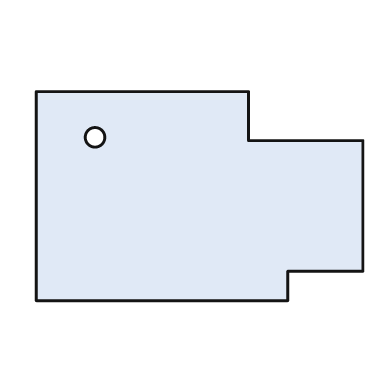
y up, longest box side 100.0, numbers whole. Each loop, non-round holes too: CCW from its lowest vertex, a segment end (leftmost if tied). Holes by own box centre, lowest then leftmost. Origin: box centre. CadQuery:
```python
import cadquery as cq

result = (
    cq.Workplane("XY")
    .moveTo(-50.0, -32.0)
    .lineTo(27.0, -32.0)
    .lineTo(27.0, -23.0)
    .lineTo(50.0, -23.0)
    .lineTo(50.0, 17.0)
    .lineTo(15.0, 17.0)
    .lineTo(15.0, 32.0)
    .lineTo(-50.0, 32.0)
    .close()
    .moveTo(-32.0, 18.0)
    .circle(3.0)
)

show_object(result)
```